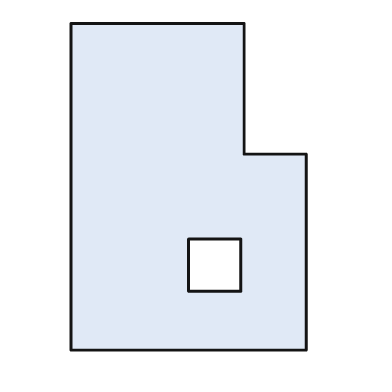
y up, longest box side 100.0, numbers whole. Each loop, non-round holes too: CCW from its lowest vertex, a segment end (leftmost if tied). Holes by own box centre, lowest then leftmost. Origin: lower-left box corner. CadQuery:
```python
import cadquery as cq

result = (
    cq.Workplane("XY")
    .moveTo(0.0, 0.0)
    .lineTo(72.0, 0.0)
    .lineTo(72.0, 60.0)
    .lineTo(53.0, 60.0)
    .lineTo(53.0, 100.0)
    .lineTo(0.0, 100.0)
    .close()
    .moveTo(36.0, 18.0)
    .lineTo(52.0, 18.0)
    .lineTo(52.0, 34.0)
    .lineTo(36.0, 34.0)
    .close()
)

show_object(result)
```